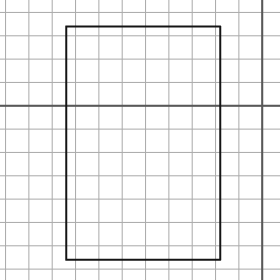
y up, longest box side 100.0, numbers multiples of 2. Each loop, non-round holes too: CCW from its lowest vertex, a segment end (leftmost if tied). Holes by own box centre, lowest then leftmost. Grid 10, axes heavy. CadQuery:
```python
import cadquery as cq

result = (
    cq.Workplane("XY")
    .moveTo(-84.0, -66.0)
    .lineTo(-18.0, -66.0)
    .lineTo(-18.0, 34.0)
    .lineTo(-84.0, 34.0)
    .close()
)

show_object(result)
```